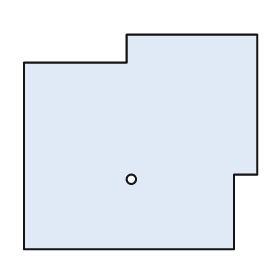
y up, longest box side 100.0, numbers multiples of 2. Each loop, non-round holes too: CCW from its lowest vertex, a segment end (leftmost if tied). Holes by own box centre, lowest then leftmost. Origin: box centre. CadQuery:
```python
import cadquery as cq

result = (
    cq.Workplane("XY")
    .moveTo(-50.0, -46.0)
    .lineTo(40.0, -46.0)
    .lineTo(40.0, -14.0)
    .lineTo(50.0, -14.0)
    .lineTo(50.0, 46.0)
    .lineTo(-6.0, 46.0)
    .lineTo(-6.0, 34.0)
    .lineTo(-50.0, 34.0)
    .close()
    .moveTo(-4.0, -16.0)
    .circle(2.0)
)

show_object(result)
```